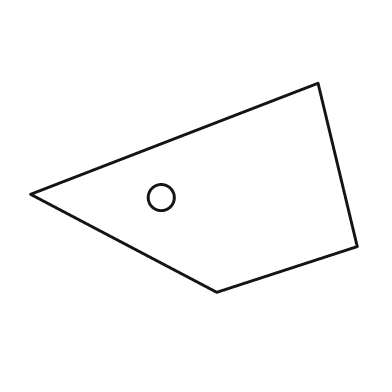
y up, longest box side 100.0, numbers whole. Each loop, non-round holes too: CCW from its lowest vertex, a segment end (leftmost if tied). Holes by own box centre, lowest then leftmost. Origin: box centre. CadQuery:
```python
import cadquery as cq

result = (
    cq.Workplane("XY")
    .moveTo(7.0, -32.0)
    .lineTo(50.0, -18.0)
    .lineTo(38.0, 32.0)
    .lineTo(-50.0, -2.0)
    .close()
    .moveTo(-10.0, -3.0)
    .circle(4.0)
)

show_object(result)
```